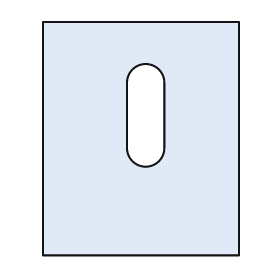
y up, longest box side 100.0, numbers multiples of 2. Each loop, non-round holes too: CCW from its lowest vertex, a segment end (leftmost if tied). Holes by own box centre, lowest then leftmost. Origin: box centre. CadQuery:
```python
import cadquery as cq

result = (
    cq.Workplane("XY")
    .moveTo(-42.0, -50.0)
    .lineTo(42.0, -50.0)
    .lineTo(42.0, 50.0)
    .lineTo(-42.0, 50.0)
    .close()
    .moveTo(-6.0, -4.0)
    .threePointArc((2.0, -12.0), (10.0, -4.0))
    .lineTo(10.0, 24.0)
    .threePointArc((2.0, 32.0), (-6.0, 24.0))
    .close()
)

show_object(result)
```